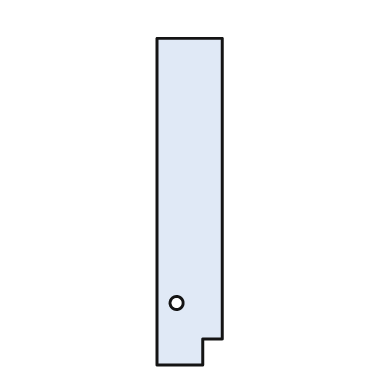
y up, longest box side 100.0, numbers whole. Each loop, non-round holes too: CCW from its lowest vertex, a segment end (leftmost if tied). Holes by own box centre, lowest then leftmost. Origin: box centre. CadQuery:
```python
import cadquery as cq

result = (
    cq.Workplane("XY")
    .moveTo(-10.0, -50.0)
    .lineTo(4.0, -50.0)
    .lineTo(4.0, -42.0)
    .lineTo(10.0, -42.0)
    .lineTo(10.0, 50.0)
    .lineTo(-10.0, 50.0)
    .close()
    .moveTo(-4.0, -31.0)
    .circle(2.0)
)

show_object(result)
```